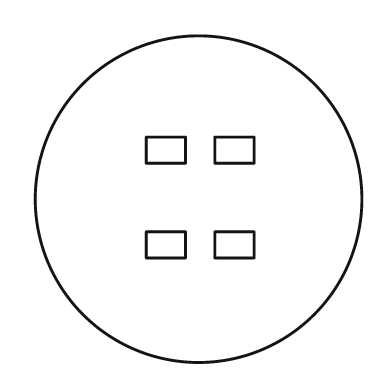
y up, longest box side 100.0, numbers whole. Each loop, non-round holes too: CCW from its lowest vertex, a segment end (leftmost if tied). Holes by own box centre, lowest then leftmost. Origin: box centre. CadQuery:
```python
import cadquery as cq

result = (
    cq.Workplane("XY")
    .moveTo(0.0, 0.0)
    .circle(50.0)
    .moveTo(-16.0, -18.0)
    .lineTo(-4.0, -18.0)
    .lineTo(-4.0, -10.0)
    .lineTo(-16.0, -10.0)
    .close()
    .moveTo(5.0, -18.0)
    .lineTo(17.0, -18.0)
    .lineTo(17.0, -10.0)
    .lineTo(5.0, -10.0)
    .close()
    .moveTo(-16.0, 11.0)
    .lineTo(-4.0, 11.0)
    .lineTo(-4.0, 19.0)
    .lineTo(-16.0, 19.0)
    .close()
    .moveTo(5.0, 11.0)
    .lineTo(17.0, 11.0)
    .lineTo(17.0, 19.0)
    .lineTo(5.0, 19.0)
    .close()
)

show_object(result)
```